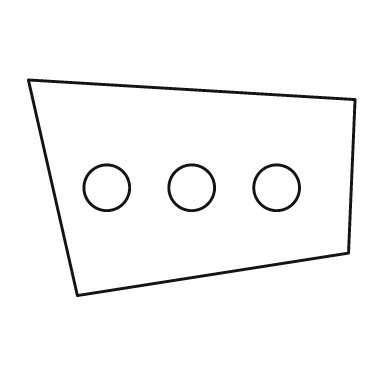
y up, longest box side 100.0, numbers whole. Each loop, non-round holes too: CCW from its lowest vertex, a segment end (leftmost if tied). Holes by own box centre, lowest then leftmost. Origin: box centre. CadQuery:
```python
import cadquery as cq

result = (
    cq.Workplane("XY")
    .moveTo(-35.0, -33.0)
    .lineTo(48.0, -20.0)
    .lineTo(50.0, 27.0)
    .lineTo(-50.0, 33.0)
    .close()
    .moveTo(-26.0, 0.0)
    .circle(7.0)
    .moveTo(0.0, 0.0)
    .circle(7.0)
    .moveTo(26.0, 0.0)
    .circle(7.0)
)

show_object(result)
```